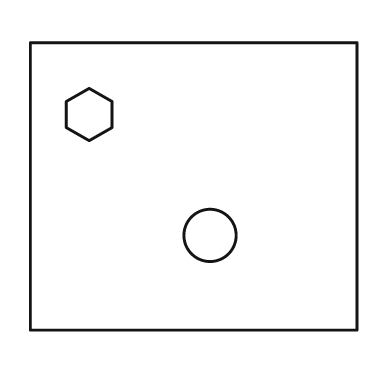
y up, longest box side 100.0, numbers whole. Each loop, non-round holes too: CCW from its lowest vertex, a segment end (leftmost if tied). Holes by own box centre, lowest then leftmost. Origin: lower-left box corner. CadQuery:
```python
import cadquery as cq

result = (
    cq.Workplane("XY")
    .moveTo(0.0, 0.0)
    .lineTo(100.0, 0.0)
    .lineTo(100.0, 88.0)
    .lineTo(0.0, 88.0)
    .close()
    .moveTo(55.0, 29.0)
    .circle(8.0)
    .moveTo(18.0, 58.0)
    .lineTo(25.0, 62.0)
    .lineTo(25.0, 70.0)
    .lineTo(18.0, 74.0)
    .lineTo(11.0, 70.0)
    .lineTo(11.0, 62.0)
    .close()
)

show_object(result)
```